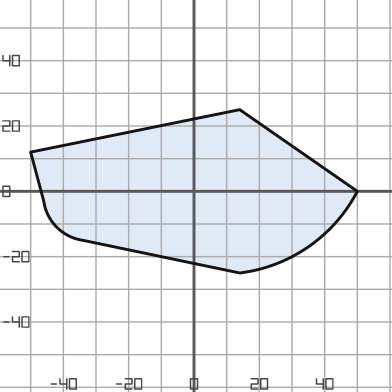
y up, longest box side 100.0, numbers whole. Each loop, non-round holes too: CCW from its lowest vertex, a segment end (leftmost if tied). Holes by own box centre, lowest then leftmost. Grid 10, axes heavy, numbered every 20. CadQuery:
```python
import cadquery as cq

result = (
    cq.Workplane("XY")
    .moveTo(14.0, -25.0)
    .threePointArc((35.0, -17.0), (50.0, 0.0))
    .lineTo(14.0, 25.0)
    .lineTo(-50.0, 12.0)
    .lineTo(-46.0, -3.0)
    .threePointArc((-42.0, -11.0), (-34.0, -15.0))
    .close()
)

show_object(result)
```